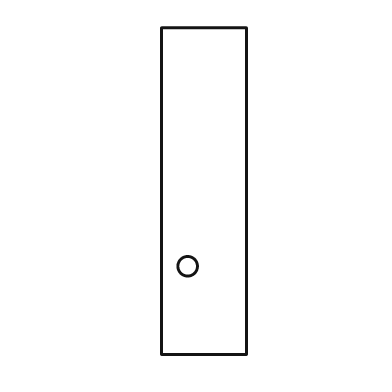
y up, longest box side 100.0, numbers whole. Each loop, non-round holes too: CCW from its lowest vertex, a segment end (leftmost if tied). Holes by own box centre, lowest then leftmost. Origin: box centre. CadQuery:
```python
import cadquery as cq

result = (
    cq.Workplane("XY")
    .moveTo(-13.0, -50.0)
    .lineTo(13.0, -50.0)
    .lineTo(13.0, 50.0)
    .lineTo(-13.0, 50.0)
    .close()
    .moveTo(-5.0, -23.0)
    .circle(3.0)
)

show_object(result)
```